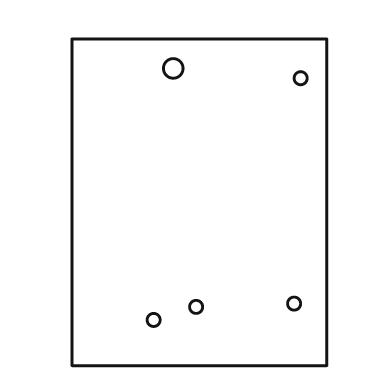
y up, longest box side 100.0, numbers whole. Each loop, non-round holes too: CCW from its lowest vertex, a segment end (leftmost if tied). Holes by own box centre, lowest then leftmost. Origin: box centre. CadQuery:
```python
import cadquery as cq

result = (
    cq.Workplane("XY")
    .moveTo(-39.0, -50.0)
    .lineTo(39.0, -50.0)
    .lineTo(39.0, 50.0)
    .lineTo(-39.0, 50.0)
    .close()
    .moveTo(-14.0, -36.0)
    .circle(2.0)
    .moveTo(-1.0, -32.0)
    .circle(2.0)
    .moveTo(29.0, -31.0)
    .circle(2.0)
    .moveTo(31.0, 38.0)
    .circle(2.0)
    .moveTo(-8.0, 41.0)
    .circle(3.0)
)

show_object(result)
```